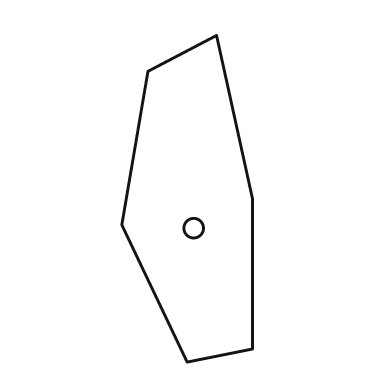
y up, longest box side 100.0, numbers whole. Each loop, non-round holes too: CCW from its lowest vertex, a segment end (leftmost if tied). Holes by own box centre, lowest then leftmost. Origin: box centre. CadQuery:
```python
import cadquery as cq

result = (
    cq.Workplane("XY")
    .moveTo(0.0, -50.0)
    .lineTo(20.0, -46.0)
    .lineTo(20.0, 0.0)
    .lineTo(9.0, 50.0)
    .lineTo(-12.0, 39.0)
    .lineTo(-20.0, -8.0)
    .close()
    .moveTo(2.0, -9.0)
    .circle(3.0)
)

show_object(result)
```